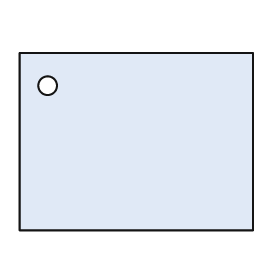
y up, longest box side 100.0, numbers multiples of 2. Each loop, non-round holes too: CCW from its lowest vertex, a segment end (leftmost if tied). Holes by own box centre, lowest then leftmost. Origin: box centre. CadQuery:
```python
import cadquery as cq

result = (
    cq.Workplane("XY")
    .moveTo(-50.0, -38.0)
    .lineTo(50.0, -38.0)
    .lineTo(50.0, 38.0)
    .lineTo(-50.0, 38.0)
    .close()
    .moveTo(-38.0, 24.0)
    .circle(4.0)
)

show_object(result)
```